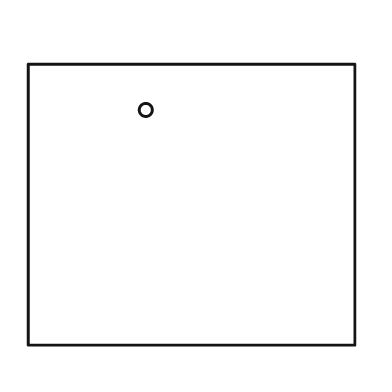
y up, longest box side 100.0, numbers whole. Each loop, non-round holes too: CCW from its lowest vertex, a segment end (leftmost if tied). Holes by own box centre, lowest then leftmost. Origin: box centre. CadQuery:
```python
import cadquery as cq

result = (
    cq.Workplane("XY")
    .moveTo(-50.0, -43.0)
    .lineTo(50.0, -43.0)
    .lineTo(50.0, 43.0)
    .lineTo(-50.0, 43.0)
    .close()
    .moveTo(-14.0, 29.0)
    .circle(2.0)
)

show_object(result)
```